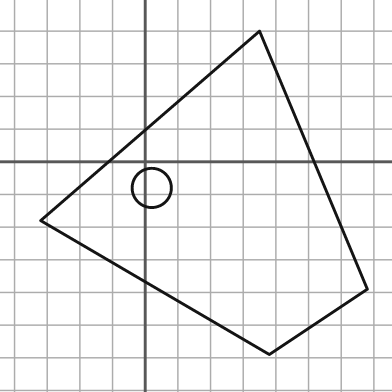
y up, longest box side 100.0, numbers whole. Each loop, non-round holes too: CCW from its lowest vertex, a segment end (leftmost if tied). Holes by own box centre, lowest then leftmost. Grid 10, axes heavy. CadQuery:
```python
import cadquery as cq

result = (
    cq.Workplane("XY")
    .moveTo(38.0, -59.0)
    .lineTo(68.0, -39.0)
    .lineTo(35.0, 40.0)
    .lineTo(-32.0, -18.0)
    .close()
    .moveTo(2.0, -8.0)
    .circle(6.0)
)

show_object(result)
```